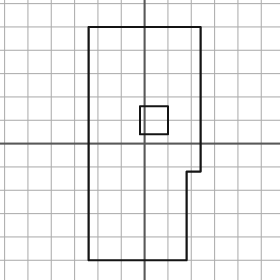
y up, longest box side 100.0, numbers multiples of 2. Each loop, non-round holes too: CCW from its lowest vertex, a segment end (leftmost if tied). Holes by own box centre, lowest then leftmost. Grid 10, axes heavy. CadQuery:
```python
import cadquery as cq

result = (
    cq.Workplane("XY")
    .moveTo(-24.0, -50.0)
    .lineTo(18.0, -50.0)
    .lineTo(18.0, -12.0)
    .lineTo(24.0, -12.0)
    .lineTo(24.0, 50.0)
    .lineTo(-24.0, 50.0)
    .close()
    .moveTo(-2.0, 4.0)
    .lineTo(10.0, 4.0)
    .lineTo(10.0, 16.0)
    .lineTo(-2.0, 16.0)
    .close()
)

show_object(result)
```